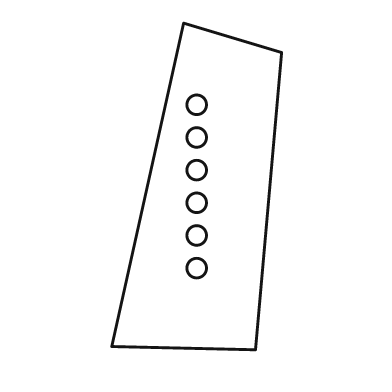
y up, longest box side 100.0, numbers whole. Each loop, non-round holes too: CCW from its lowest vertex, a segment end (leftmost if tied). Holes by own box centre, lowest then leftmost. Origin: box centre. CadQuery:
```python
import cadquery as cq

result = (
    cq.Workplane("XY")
    .moveTo(18.0, -50.0)
    .lineTo(26.0, 41.0)
    .lineTo(-4.0, 50.0)
    .lineTo(-26.0, -49.0)
    .close()
    .moveTo(0.0, -25.0)
    .circle(3.0)
    .moveTo(0.0, -15.0)
    .circle(3.0)
    .moveTo(0.0, -5.0)
    .circle(3.0)
    .moveTo(0.0, 5.0)
    .circle(3.0)
    .moveTo(0.0, 15.0)
    .circle(3.0)
    .moveTo(0.0, 25.0)
    .circle(3.0)
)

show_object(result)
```